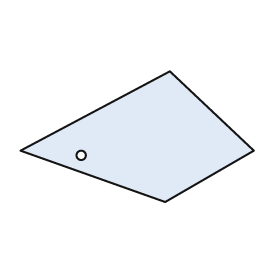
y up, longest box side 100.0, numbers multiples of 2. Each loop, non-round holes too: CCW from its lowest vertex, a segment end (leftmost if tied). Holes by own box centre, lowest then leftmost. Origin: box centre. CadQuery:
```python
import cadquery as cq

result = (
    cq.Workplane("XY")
    .moveTo(12.0, -28.0)
    .lineTo(50.0, -6.0)
    .lineTo(14.0, 28.0)
    .lineTo(-50.0, -6.0)
    .close()
    .moveTo(-24.0, -8.0)
    .circle(2.0)
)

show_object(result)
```